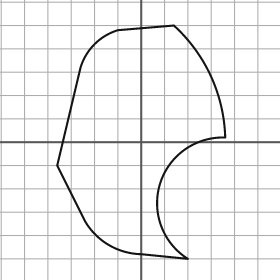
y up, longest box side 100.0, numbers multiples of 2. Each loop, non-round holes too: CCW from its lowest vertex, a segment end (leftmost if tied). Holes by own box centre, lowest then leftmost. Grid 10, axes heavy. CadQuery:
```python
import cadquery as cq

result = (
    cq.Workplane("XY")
    .moveTo(20.0, -50.0)
    .threePointArc((8.0, -18.0), (36.0, 2.0))
    .threePointArc((30.0, 28.0), (14.0, 50.0))
    .lineTo(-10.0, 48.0)
    .threePointArc((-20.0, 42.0), (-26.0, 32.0))
    .lineTo(-36.0, -10.0)
    .lineTo(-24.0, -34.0)
    .threePointArc((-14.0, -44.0), (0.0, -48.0))
    .close()
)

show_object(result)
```